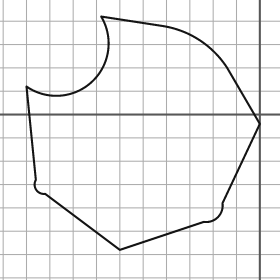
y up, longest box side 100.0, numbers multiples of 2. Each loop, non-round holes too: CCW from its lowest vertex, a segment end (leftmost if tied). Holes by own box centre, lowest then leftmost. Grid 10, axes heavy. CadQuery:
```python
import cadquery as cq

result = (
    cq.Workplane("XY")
    .moveTo(-60.0, -58.0)
    .lineTo(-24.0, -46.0)
    .threePointArc((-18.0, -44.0), (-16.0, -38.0))
    .lineTo(0.0, -4.0)
    .lineTo(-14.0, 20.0)
    .threePointArc((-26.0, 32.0), (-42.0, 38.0))
    .lineTo(-68.0, 42.0)
    .threePointArc((-72.0, 14.0), (-100.0, 12.0))
    .lineTo(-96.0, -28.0)
    .threePointArc((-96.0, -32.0), (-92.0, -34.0))
    .close()
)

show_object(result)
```